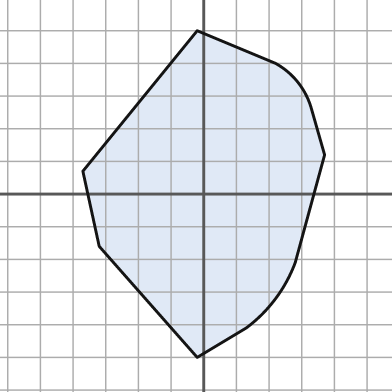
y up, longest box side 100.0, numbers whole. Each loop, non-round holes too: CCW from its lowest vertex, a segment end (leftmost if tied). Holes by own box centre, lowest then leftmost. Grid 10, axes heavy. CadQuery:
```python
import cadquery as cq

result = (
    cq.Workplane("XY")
    .moveTo(-2.0, -50.0)
    .lineTo(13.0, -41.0)
    .threePointArc((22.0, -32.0), (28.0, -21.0))
    .lineTo(37.0, 12.0)
    .lineTo(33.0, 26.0)
    .threePointArc((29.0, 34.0), (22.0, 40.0))
    .lineTo(-2.0, 50.0)
    .lineTo(-37.0, 7.0)
    .lineTo(-32.0, -16.0)
    .close()
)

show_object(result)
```